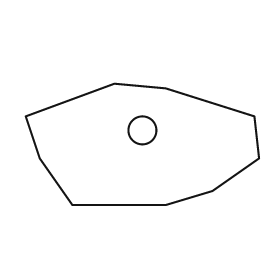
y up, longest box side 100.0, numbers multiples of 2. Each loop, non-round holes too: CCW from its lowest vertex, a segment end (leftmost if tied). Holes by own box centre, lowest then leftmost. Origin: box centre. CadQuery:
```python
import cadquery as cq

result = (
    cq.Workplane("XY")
    .moveTo(-30.0, -26.0)
    .lineTo(10.0, -26.0)
    .lineTo(30.0, -20.0)
    .lineTo(50.0, -6.0)
    .lineTo(48.0, 12.0)
    .lineTo(10.0, 24.0)
    .lineTo(-12.0, 26.0)
    .lineTo(-50.0, 12.0)
    .lineTo(-44.0, -6.0)
    .close()
    .moveTo(0.0, 6.0)
    .circle(6.0)
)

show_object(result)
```